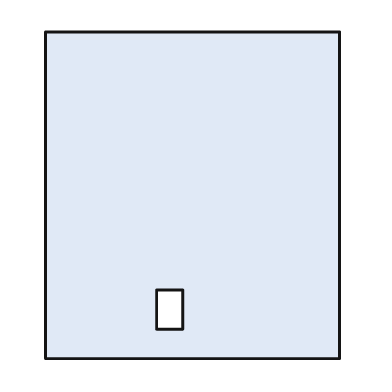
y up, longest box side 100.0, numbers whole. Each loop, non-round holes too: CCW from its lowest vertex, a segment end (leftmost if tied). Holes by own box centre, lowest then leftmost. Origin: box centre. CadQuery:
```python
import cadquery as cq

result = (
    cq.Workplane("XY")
    .moveTo(-45.0, -50.0)
    .lineTo(45.0, -50.0)
    .lineTo(45.0, 50.0)
    .lineTo(-45.0, 50.0)
    .close()
    .moveTo(-11.0, -41.0)
    .lineTo(-3.0, -41.0)
    .lineTo(-3.0, -29.0)
    .lineTo(-11.0, -29.0)
    .close()
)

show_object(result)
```